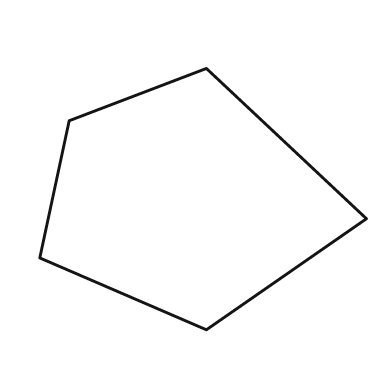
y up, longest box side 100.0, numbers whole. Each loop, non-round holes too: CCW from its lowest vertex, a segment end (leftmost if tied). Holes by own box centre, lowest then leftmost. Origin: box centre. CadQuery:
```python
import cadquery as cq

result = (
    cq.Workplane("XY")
    .moveTo(1.0, -40.0)
    .lineTo(50.0, -6.0)
    .lineTo(1.0, 40.0)
    .lineTo(-41.0, 24.0)
    .lineTo(-50.0, -18.0)
    .close()
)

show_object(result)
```